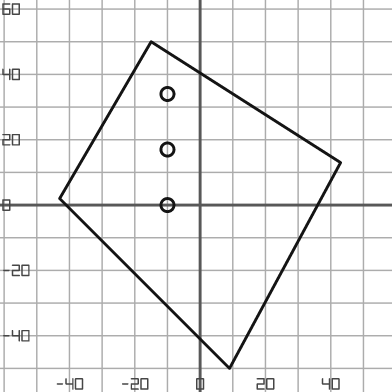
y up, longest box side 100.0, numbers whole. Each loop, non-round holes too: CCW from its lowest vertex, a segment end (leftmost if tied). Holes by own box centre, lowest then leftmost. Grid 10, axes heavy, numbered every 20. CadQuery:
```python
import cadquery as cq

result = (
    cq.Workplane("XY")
    .moveTo(9.0, -50.0)
    .lineTo(43.0, 13.0)
    .lineTo(-15.0, 50.0)
    .lineTo(-43.0, 2.0)
    .close()
    .moveTo(-10.0, 0.0)
    .circle(2.0)
    .moveTo(-10.0, 17.0)
    .circle(2.0)
    .moveTo(-10.0, 34.0)
    .circle(2.0)
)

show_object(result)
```